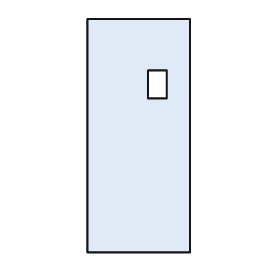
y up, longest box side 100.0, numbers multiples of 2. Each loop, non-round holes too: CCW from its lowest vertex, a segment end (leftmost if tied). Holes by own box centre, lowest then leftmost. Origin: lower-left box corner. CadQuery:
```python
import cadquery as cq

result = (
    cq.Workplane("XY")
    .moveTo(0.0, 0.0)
    .lineTo(44.0, 0.0)
    .lineTo(44.0, 100.0)
    .lineTo(0.0, 100.0)
    .close()
    .moveTo(26.0, 66.0)
    .lineTo(34.0, 66.0)
    .lineTo(34.0, 78.0)
    .lineTo(26.0, 78.0)
    .close()
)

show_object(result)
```